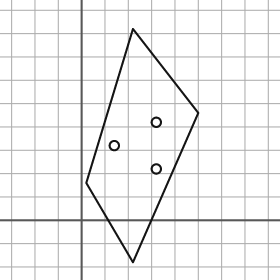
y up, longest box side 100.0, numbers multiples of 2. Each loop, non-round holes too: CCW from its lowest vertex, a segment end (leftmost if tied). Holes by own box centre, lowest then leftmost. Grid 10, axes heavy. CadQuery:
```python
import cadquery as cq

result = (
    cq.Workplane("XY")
    .moveTo(22.0, -18.0)
    .lineTo(50.0, 46.0)
    .lineTo(22.0, 82.0)
    .lineTo(2.0, 16.0)
    .close()
    .moveTo(32.0, 22.0)
    .circle(2.0)
    .moveTo(14.0, 32.0)
    .circle(2.0)
    .moveTo(32.0, 42.0)
    .circle(2.0)
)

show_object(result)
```